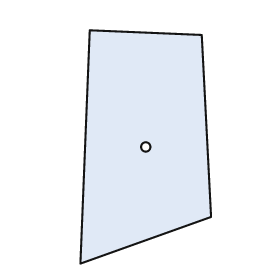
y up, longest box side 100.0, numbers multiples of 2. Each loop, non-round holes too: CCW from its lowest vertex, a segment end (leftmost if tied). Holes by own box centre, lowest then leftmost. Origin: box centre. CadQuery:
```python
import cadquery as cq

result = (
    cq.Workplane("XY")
    .moveTo(-28.0, -50.0)
    .lineTo(28.0, -30.0)
    .lineTo(24.0, 48.0)
    .lineTo(-24.0, 50.0)
    .close()
    .moveTo(0.0, 0.0)
    .circle(2.0)
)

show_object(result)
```